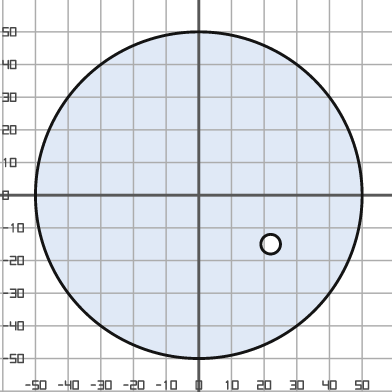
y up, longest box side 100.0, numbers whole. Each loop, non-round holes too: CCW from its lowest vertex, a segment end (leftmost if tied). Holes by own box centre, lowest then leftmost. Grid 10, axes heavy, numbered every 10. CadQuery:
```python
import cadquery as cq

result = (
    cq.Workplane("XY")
    .moveTo(0.0, 0.0)
    .circle(50.0)
    .moveTo(22.0, -15.0)
    .circle(3.0)
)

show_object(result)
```